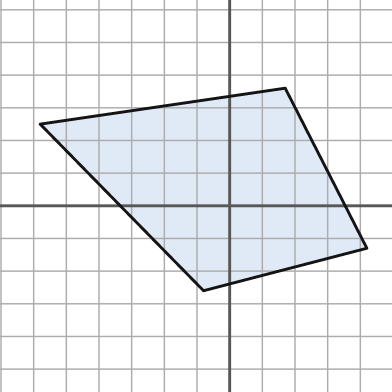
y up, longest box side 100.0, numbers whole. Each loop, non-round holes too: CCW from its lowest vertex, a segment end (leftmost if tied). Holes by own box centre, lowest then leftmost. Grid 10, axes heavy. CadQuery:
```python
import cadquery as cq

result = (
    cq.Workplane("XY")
    .moveTo(-8.0, -26.0)
    .lineTo(42.0, -13.0)
    .lineTo(17.0, 36.0)
    .lineTo(-58.0, 25.0)
    .close()
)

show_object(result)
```